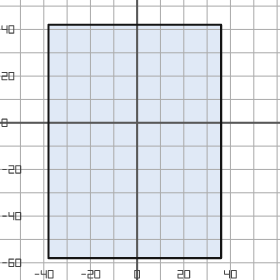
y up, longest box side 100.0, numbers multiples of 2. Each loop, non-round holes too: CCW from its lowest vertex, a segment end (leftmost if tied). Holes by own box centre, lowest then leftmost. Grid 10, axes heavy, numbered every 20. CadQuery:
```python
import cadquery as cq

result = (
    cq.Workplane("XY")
    .moveTo(-38.0, -58.0)
    .lineTo(36.0, -58.0)
    .lineTo(36.0, 42.0)
    .lineTo(-38.0, 42.0)
    .close()
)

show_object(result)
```